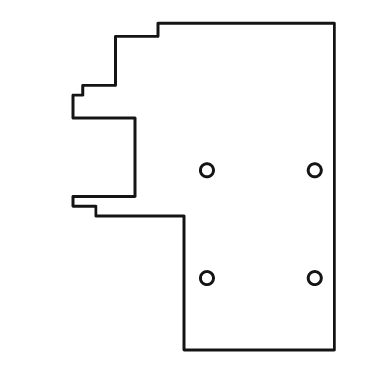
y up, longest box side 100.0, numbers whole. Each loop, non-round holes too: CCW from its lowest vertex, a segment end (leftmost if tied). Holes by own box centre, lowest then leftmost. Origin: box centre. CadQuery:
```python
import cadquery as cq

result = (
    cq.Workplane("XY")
    .moveTo(-6.0, -50.0)
    .lineTo(40.0, -50.0)
    .lineTo(40.0, 50.0)
    .lineTo(-14.0, 50.0)
    .lineTo(-14.0, 46.0)
    .lineTo(-27.0, 46.0)
    .lineTo(-27.0, 31.0)
    .lineTo(-37.0, 31.0)
    .lineTo(-37.0, 28.0)
    .lineTo(-40.0, 28.0)
    .lineTo(-40.0, 21.0)
    .lineTo(-21.0, 21.0)
    .lineTo(-21.0, -3.0)
    .lineTo(-40.0, -3.0)
    .lineTo(-40.0, -6.0)
    .lineTo(-33.0, -6.0)
    .lineTo(-33.0, -9.0)
    .lineTo(-6.0, -9.0)
    .close()
    .moveTo(1.0, -28.0)
    .circle(2.0)
    .moveTo(34.0, -28.0)
    .circle(2.0)
    .moveTo(1.0, 5.0)
    .circle(2.0)
    .moveTo(34.0, 5.0)
    .circle(2.0)
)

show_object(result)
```